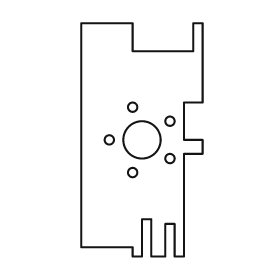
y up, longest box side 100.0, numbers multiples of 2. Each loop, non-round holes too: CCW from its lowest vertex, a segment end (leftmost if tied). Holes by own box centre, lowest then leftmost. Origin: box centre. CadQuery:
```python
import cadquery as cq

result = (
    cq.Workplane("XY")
    .moveTo(-4.0, -50.0)
    .lineTo(0.0, -50.0)
    .lineTo(0.0, -34.0)
    .lineTo(4.0, -34.0)
    .lineTo(4.0, -50.0)
    .lineTo(10.0, -50.0)
    .lineTo(10.0, -36.0)
    .lineTo(14.0, -36.0)
    .lineTo(14.0, -50.0)
    .lineTo(18.0, -50.0)
    .lineTo(18.0, -6.0)
    .lineTo(26.0, -6.0)
    .lineTo(26.0, 0.0)
    .lineTo(18.0, 0.0)
    .lineTo(18.0, 16.0)
    .lineTo(26.0, 16.0)
    .lineTo(26.0, 50.0)
    .lineTo(22.0, 50.0)
    .lineTo(22.0, 38.0)
    .lineTo(-4.0, 38.0)
    .lineTo(-4.0, 50.0)
    .lineTo(-26.0, 50.0)
    .lineTo(-26.0, -46.0)
    .lineTo(-4.0, -46.0)
    .close()
    .moveTo(-4.0, -14.0)
    .circle(2.0)
    .moveTo(12.0, -8.0)
    .circle(2.0)
    .moveTo(-14.0, 0.0)
    .circle(2.0)
    .moveTo(0.0, 0.0)
    .circle(8.0)
    .moveTo(12.0, 8.0)
    .circle(2.0)
    .moveTo(-4.0, 14.0)
    .circle(2.0)
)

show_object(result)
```